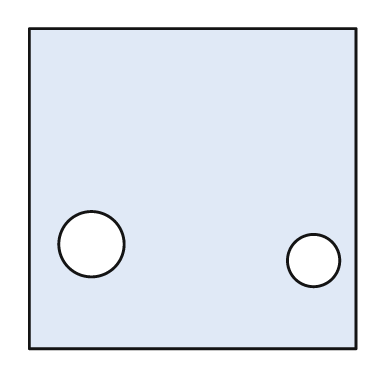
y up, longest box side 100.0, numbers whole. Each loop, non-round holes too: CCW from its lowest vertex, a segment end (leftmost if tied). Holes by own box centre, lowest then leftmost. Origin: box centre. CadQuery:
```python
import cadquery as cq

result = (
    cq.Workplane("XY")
    .moveTo(-50.0, -49.0)
    .lineTo(50.0, -49.0)
    .lineTo(50.0, 49.0)
    .lineTo(-50.0, 49.0)
    .close()
    .moveTo(37.0, -22.0)
    .circle(8.0)
    .moveTo(-31.0, -17.0)
    .circle(10.0)
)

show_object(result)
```